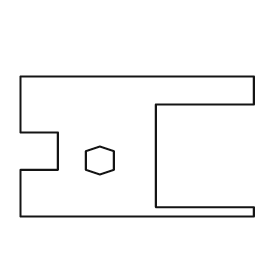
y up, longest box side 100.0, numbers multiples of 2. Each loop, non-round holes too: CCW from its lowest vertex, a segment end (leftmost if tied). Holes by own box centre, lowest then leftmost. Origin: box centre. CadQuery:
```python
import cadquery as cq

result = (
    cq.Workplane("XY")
    .moveTo(-50.0, -30.0)
    .lineTo(50.0, -30.0)
    .lineTo(50.0, -26.0)
    .lineTo(8.0, -26.0)
    .lineTo(8.0, 18.0)
    .lineTo(50.0, 18.0)
    .lineTo(50.0, 30.0)
    .lineTo(-50.0, 30.0)
    .lineTo(-50.0, 6.0)
    .lineTo(-34.0, 6.0)
    .lineTo(-34.0, -10.0)
    .lineTo(-50.0, -10.0)
    .close()
    .moveTo(-16.0, -12.0)
    .lineTo(-10.0, -10.0)
    .lineTo(-10.0, -2.0)
    .lineTo(-16.0, 0.0)
    .lineTo(-22.0, -2.0)
    .lineTo(-22.0, -10.0)
    .close()
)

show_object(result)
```